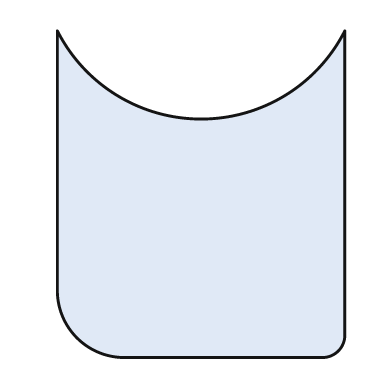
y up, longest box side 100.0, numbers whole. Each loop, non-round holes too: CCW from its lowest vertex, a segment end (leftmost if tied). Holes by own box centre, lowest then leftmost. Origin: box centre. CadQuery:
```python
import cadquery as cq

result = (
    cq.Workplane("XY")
    .moveTo(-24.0, -50.0)
    .lineTo(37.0, -50.0)
    .threePointArc((42.0, -48.0), (44.0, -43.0))
    .lineTo(44.0, 50.0)
    .threePointArc((0.0, 23.0), (-44.0, 50.0))
    .lineTo(-44.0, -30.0)
    .threePointArc((-38.0, -44.0), (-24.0, -50.0))
    .close()
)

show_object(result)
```